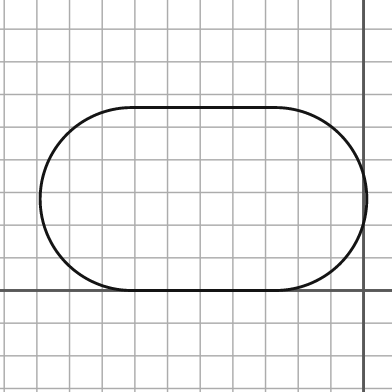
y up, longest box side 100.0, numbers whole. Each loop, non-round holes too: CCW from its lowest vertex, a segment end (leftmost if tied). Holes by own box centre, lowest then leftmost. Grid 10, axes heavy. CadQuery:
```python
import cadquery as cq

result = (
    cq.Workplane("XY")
    .moveTo(-71.0, 0.0)
    .lineTo(-27.0, 0.0)
    .threePointArc((1.0, 28.0), (-27.0, 56.0))
    .lineTo(-71.0, 56.0)
    .threePointArc((-99.0, 28.0), (-71.0, 0.0))
    .close()
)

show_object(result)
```